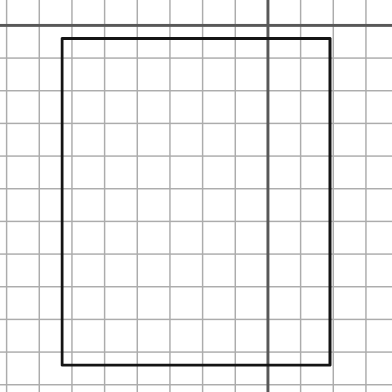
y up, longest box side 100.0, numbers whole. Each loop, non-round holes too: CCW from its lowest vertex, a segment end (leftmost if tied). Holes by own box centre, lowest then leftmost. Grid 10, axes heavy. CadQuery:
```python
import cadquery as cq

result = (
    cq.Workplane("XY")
    .moveTo(-63.0, -104.0)
    .lineTo(19.0, -104.0)
    .lineTo(19.0, -4.0)
    .lineTo(-63.0, -4.0)
    .close()
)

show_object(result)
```